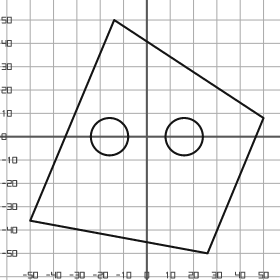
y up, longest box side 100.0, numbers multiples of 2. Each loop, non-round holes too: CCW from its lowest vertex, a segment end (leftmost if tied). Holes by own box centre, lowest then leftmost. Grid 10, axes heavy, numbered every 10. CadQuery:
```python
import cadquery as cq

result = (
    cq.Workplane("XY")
    .moveTo(26.0, -50.0)
    .lineTo(50.0, 8.0)
    .lineTo(-14.0, 50.0)
    .lineTo(-50.0, -36.0)
    .close()
    .moveTo(-16.0, 0.0)
    .circle(8.0)
    .moveTo(16.0, 0.0)
    .circle(8.0)
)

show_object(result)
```